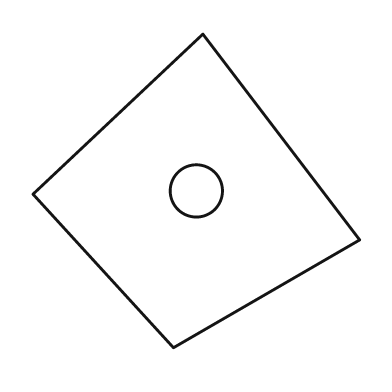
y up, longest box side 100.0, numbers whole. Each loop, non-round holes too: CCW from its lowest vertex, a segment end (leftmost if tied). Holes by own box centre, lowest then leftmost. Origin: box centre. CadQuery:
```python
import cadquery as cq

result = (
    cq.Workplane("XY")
    .moveTo(-7.0, -48.0)
    .lineTo(50.0, -15.0)
    .lineTo(2.0, 48.0)
    .lineTo(-50.0, -1.0)
    .close()
    .moveTo(0.0, 0.0)
    .circle(8.0)
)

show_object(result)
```